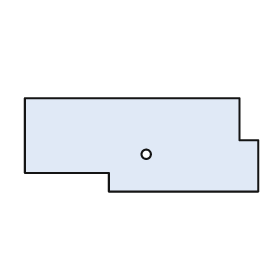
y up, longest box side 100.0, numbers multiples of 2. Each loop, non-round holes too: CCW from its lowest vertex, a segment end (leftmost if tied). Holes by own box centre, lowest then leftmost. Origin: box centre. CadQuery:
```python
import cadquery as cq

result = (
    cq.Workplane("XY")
    .moveTo(-14.0, -20.0)
    .lineTo(50.0, -20.0)
    .lineTo(50.0, 2.0)
    .lineTo(42.0, 2.0)
    .lineTo(42.0, 20.0)
    .lineTo(-50.0, 20.0)
    .lineTo(-50.0, -12.0)
    .lineTo(-14.0, -12.0)
    .close()
    .moveTo(2.0, -4.0)
    .circle(2.0)
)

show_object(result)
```